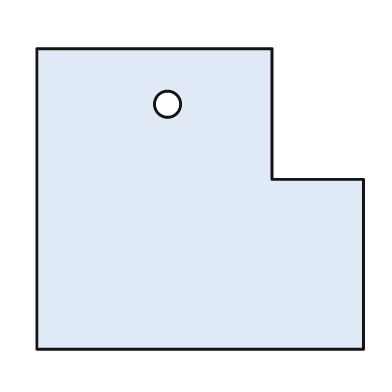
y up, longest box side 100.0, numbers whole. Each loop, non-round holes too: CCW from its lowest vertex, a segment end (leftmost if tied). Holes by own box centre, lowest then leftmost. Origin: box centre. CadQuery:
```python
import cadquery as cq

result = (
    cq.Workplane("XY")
    .moveTo(-50.0, -46.0)
    .lineTo(50.0, -46.0)
    .lineTo(50.0, 6.0)
    .lineTo(22.0, 6.0)
    .lineTo(22.0, 46.0)
    .lineTo(-50.0, 46.0)
    .close()
    .moveTo(-10.0, 29.0)
    .circle(4.0)
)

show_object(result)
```